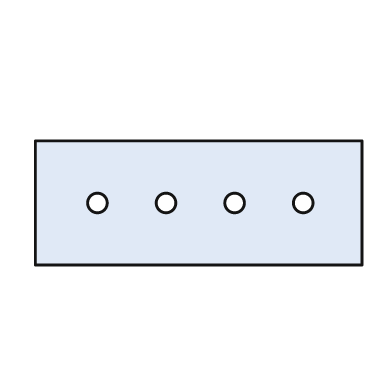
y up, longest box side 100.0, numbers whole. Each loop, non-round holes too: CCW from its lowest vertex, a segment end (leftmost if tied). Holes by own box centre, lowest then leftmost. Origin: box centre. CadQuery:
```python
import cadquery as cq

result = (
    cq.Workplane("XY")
    .moveTo(-50.0, -19.0)
    .lineTo(50.0, -19.0)
    .lineTo(50.0, 19.0)
    .lineTo(-50.0, 19.0)
    .close()
    .moveTo(-31.0, 0.0)
    .circle(3.0)
    .moveTo(-10.0, 0.0)
    .circle(3.0)
    .moveTo(11.0, 0.0)
    .circle(3.0)
    .moveTo(32.0, 0.0)
    .circle(3.0)
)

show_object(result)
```